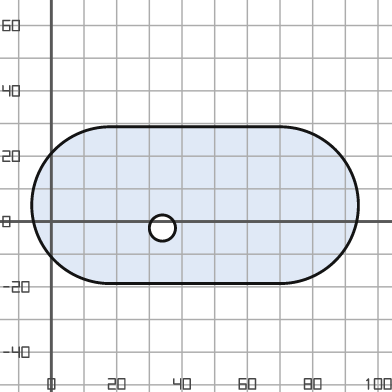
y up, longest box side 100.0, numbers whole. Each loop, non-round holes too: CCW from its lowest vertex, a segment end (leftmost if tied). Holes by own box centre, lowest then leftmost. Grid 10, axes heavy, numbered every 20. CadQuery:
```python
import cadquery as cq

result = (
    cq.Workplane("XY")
    .moveTo(18.0, -19.0)
    .lineTo(70.0, -19.0)
    .threePointArc((94.0, 5.0), (70.0, 29.0))
    .lineTo(18.0, 29.0)
    .threePointArc((-6.0, 5.0), (18.0, -19.0))
    .close()
    .moveTo(34.0, -2.0)
    .circle(4.0)
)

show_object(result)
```